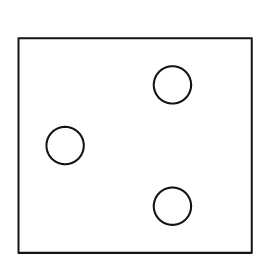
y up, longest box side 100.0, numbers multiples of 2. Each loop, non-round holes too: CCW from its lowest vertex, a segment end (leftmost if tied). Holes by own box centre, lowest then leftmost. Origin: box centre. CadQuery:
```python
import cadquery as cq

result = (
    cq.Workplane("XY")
    .moveTo(-50.0, -46.0)
    .lineTo(50.0, -46.0)
    .lineTo(50.0, 46.0)
    .lineTo(-50.0, 46.0)
    .close()
    .moveTo(16.0, -26.0)
    .circle(8.0)
    .moveTo(-30.0, 0.0)
    .circle(8.0)
    .moveTo(16.0, 26.0)
    .circle(8.0)
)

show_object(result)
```